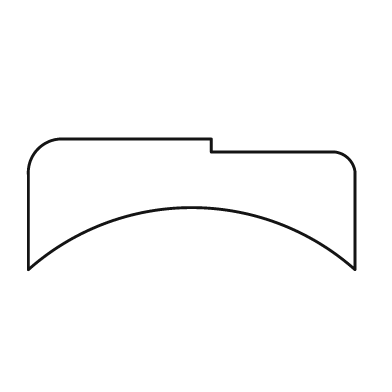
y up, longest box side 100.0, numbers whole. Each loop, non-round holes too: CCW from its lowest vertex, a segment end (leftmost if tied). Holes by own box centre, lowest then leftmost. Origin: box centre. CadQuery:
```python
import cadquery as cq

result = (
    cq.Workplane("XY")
    .moveTo(-50.0, -20.0)
    .threePointArc((0.0, -1.0), (50.0, -20.0))
    .lineTo(50.0, 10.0)
    .threePointArc((48.0, 14.0), (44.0, 16.0))
    .lineTo(6.0, 16.0)
    .lineTo(6.0, 20.0)
    .lineTo(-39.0, 20.0)
    .threePointArc((-47.0, 17.0), (-50.0, 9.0))
    .close()
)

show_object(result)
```